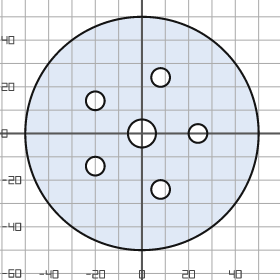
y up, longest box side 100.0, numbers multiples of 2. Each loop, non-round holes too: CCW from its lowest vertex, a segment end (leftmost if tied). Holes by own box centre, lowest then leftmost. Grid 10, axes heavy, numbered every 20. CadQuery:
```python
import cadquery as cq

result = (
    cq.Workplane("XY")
    .moveTo(0.0, 0.0)
    .circle(50.0)
    .moveTo(8.0, -24.0)
    .circle(4.0)
    .moveTo(-20.0, -14.0)
    .circle(4.0)
    .moveTo(0.0, 0.0)
    .circle(6.0)
    .moveTo(24.0, 0.0)
    .circle(4.0)
    .moveTo(-20.0, 14.0)
    .circle(4.0)
    .moveTo(8.0, 24.0)
    .circle(4.0)
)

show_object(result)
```